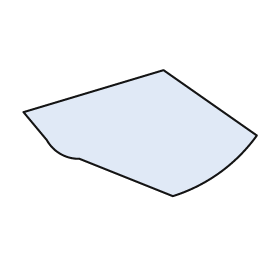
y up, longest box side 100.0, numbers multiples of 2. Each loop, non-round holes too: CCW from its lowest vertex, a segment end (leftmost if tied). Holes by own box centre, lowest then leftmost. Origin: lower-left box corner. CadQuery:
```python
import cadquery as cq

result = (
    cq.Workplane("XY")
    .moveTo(64.0, 0.0)
    .threePointArc((84.0, 10.0), (100.0, 26.0))
    .lineTo(60.0, 54.0)
    .lineTo(0.0, 36.0)
    .lineTo(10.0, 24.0)
    .threePointArc((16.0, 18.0), (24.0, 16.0))
    .close()
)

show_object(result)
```